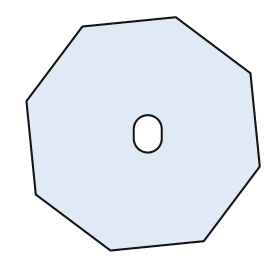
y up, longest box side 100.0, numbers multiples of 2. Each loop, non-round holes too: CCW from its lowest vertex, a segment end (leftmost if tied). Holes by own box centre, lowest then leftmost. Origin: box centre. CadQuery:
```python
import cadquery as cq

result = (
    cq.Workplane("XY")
    .moveTo(-14.0, -50.0)
    .lineTo(26.0, -46.0)
    .lineTo(50.0, -14.0)
    .lineTo(46.0, 26.0)
    .lineTo(14.0, 50.0)
    .lineTo(-26.0, 46.0)
    .lineTo(-50.0, 14.0)
    .lineTo(-46.0, -26.0)
    .close()
    .moveTo(-4.0, -2.0)
    .threePointArc((2.0, -8.0), (8.0, -2.0))
    .lineTo(8.0, 2.0)
    .threePointArc((2.0, 8.0), (-4.0, 2.0))
    .close()
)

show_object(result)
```